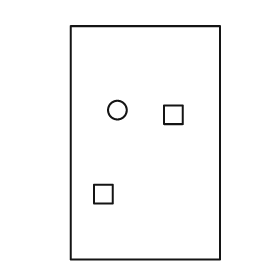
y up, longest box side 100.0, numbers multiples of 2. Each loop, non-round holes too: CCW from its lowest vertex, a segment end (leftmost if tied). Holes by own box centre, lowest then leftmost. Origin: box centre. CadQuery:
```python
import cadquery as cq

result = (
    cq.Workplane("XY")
    .moveTo(-32.0, -50.0)
    .lineTo(32.0, -50.0)
    .lineTo(32.0, 50.0)
    .lineTo(-32.0, 50.0)
    .close()
    .moveTo(-22.0, -26.0)
    .lineTo(-14.0, -26.0)
    .lineTo(-14.0, -18.0)
    .lineTo(-22.0, -18.0)
    .close()
    .moveTo(8.0, 8.0)
    .lineTo(16.0, 8.0)
    .lineTo(16.0, 16.0)
    .lineTo(8.0, 16.0)
    .close()
    .moveTo(-12.0, 14.0)
    .circle(4.0)
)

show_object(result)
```